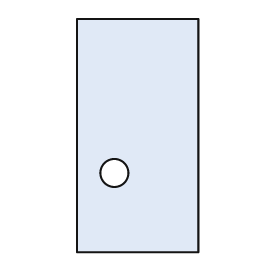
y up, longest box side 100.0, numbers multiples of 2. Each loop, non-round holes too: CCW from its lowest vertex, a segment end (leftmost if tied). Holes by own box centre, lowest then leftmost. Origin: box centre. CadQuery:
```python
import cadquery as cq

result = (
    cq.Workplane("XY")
    .moveTo(-26.0, -50.0)
    .lineTo(26.0, -50.0)
    .lineTo(26.0, 50.0)
    .lineTo(-26.0, 50.0)
    .close()
    .moveTo(-10.0, -16.0)
    .circle(6.0)
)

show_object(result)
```